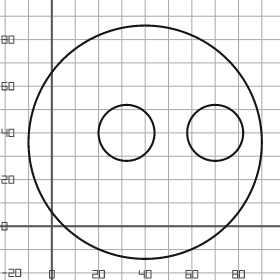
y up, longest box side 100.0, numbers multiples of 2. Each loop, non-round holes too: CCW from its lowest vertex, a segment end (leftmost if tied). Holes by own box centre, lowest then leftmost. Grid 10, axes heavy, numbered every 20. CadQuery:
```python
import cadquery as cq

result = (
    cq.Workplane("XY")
    .moveTo(40.0, 36.0)
    .circle(50.0)
    .moveTo(32.0, 40.0)
    .circle(12.0)
    .moveTo(70.0, 40.0)
    .circle(12.0)
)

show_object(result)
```